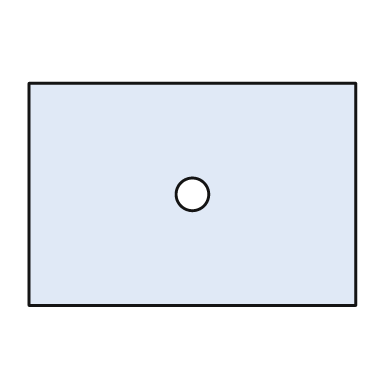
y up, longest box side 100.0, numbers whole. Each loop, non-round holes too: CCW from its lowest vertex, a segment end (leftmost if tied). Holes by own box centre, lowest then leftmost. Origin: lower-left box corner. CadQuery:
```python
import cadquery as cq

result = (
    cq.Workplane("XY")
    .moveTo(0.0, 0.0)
    .lineTo(100.0, 0.0)
    .lineTo(100.0, 68.0)
    .lineTo(0.0, 68.0)
    .close()
    .moveTo(50.0, 34.0)
    .circle(5.0)
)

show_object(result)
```